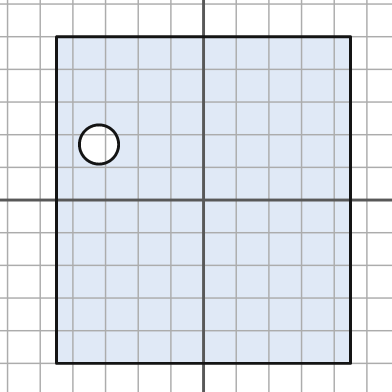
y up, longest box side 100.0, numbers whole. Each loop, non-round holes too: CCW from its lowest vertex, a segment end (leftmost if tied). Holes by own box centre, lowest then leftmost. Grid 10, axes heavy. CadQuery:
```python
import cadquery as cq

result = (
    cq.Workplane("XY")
    .moveTo(-45.0, -50.0)
    .lineTo(45.0, -50.0)
    .lineTo(45.0, 50.0)
    .lineTo(-45.0, 50.0)
    .close()
    .moveTo(-32.0, 17.0)
    .circle(6.0)
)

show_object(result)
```